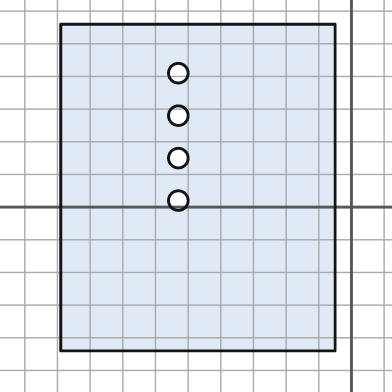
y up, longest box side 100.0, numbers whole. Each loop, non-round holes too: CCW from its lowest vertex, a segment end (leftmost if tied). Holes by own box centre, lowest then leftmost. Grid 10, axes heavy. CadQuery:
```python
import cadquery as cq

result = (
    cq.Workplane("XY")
    .moveTo(-89.0, -44.0)
    .lineTo(-5.0, -44.0)
    .lineTo(-5.0, 56.0)
    .lineTo(-89.0, 56.0)
    .close()
    .moveTo(-53.0, 2.0)
    .circle(3.0)
    .moveTo(-53.0, 15.0)
    .circle(3.0)
    .moveTo(-53.0, 28.0)
    .circle(3.0)
    .moveTo(-53.0, 41.0)
    .circle(3.0)
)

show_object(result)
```